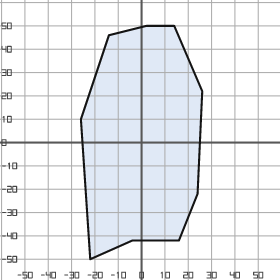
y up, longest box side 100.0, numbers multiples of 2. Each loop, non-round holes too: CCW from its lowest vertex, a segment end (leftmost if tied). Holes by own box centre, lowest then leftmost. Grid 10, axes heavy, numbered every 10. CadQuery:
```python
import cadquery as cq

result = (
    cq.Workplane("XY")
    .moveTo(-22.0, -50.0)
    .lineTo(-4.0, -42.0)
    .lineTo(16.0, -42.0)
    .lineTo(24.0, -22.0)
    .lineTo(26.0, 22.0)
    .lineTo(14.0, 50.0)
    .lineTo(2.0, 50.0)
    .lineTo(-14.0, 46.0)
    .lineTo(-26.0, 10.0)
    .close()
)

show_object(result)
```